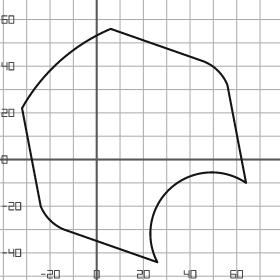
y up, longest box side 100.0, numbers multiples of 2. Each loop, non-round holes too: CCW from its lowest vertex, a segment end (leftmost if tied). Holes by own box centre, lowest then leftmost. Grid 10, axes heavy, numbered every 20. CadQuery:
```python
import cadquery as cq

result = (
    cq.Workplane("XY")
    .moveTo(26.0, -44.0)
    .threePointArc((32.0, -12.0), (64.0, -10.0))
    .lineTo(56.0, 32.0)
    .threePointArc((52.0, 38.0), (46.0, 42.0))
    .lineTo(6.0, 56.0)
    .threePointArc((-16.0, 42.0), (-32.0, 22.0))
    .lineTo(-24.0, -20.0)
    .threePointArc((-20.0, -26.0), (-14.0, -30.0))
    .close()
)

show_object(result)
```